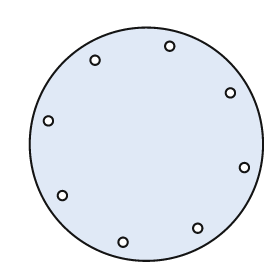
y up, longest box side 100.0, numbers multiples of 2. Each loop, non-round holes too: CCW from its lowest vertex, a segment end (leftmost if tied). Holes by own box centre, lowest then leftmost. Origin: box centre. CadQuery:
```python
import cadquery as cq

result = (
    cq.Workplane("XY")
    .moveTo(0.0, 0.0)
    .circle(50.0)
    .moveTo(-10.0, -42.0)
    .circle(2.0)
    .moveTo(22.0, -36.0)
    .circle(2.0)
    .moveTo(-36.0, -22.0)
    .circle(2.0)
    .moveTo(42.0, -10.0)
    .circle(2.0)
    .moveTo(-42.0, 10.0)
    .circle(2.0)
    .moveTo(36.0, 22.0)
    .circle(2.0)
    .moveTo(-22.0, 36.0)
    .circle(2.0)
    .moveTo(10.0, 42.0)
    .circle(2.0)
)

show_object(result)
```